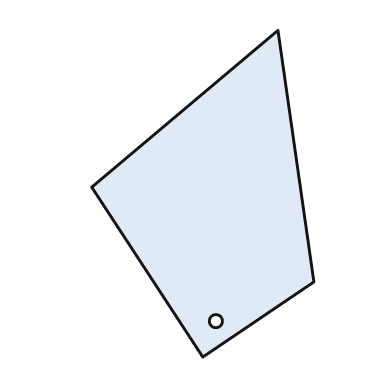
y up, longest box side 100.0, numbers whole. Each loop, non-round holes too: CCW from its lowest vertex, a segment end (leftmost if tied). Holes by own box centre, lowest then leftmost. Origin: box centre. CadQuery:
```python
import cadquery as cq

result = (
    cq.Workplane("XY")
    .moveTo(0.0, -50.0)
    .lineTo(34.0, -27.0)
    .lineTo(23.0, 50.0)
    .lineTo(-34.0, 2.0)
    .close()
    .moveTo(4.0, -39.0)
    .circle(2.0)
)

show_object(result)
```